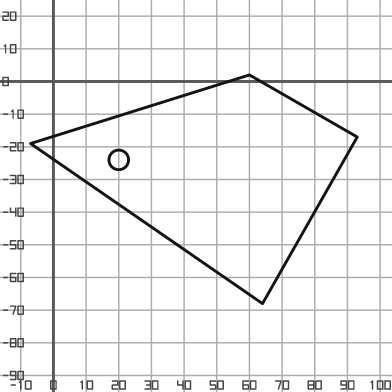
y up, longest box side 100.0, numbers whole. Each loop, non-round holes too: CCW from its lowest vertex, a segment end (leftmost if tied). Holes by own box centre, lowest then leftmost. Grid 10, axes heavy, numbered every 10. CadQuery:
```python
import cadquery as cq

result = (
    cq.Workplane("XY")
    .moveTo(64.0, -68.0)
    .lineTo(93.0, -17.0)
    .lineTo(60.0, 2.0)
    .lineTo(-7.0, -19.0)
    .close()
    .moveTo(20.0, -24.0)
    .circle(3.0)
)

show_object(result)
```